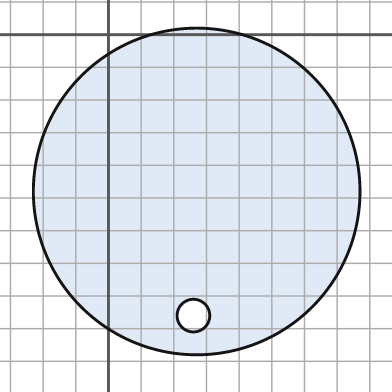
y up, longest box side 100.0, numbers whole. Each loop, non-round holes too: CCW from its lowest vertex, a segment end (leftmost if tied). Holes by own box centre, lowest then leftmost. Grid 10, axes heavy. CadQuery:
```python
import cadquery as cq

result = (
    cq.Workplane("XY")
    .moveTo(27.0, -48.0)
    .circle(50.0)
    .moveTo(26.0, -86.0)
    .circle(5.0)
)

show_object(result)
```